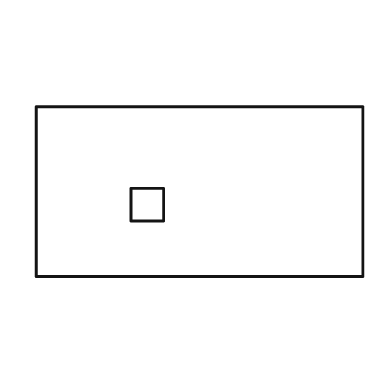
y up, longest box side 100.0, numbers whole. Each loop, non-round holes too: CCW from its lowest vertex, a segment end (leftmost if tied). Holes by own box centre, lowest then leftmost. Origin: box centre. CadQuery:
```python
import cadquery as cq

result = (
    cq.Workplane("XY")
    .moveTo(-50.0, -26.0)
    .lineTo(50.0, -26.0)
    .lineTo(50.0, 26.0)
    .lineTo(-50.0, 26.0)
    .close()
    .moveTo(-21.0, -9.0)
    .lineTo(-11.0, -9.0)
    .lineTo(-11.0, 1.0)
    .lineTo(-21.0, 1.0)
    .close()
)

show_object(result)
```